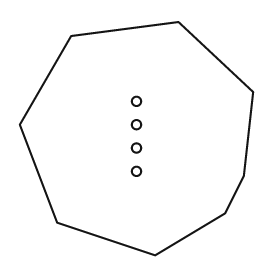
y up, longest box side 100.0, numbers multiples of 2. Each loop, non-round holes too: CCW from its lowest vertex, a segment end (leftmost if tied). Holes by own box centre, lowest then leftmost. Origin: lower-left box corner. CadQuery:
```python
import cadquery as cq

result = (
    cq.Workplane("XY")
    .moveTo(58.0, 0.0)
    .lineTo(88.0, 18.0)
    .lineTo(96.0, 34.0)
    .lineTo(100.0, 70.0)
    .lineTo(68.0, 100.0)
    .lineTo(22.0, 94.0)
    .lineTo(0.0, 56.0)
    .lineTo(16.0, 14.0)
    .close()
    .moveTo(50.0, 36.0)
    .circle(2.0)
    .moveTo(50.0, 46.0)
    .circle(2.0)
    .moveTo(50.0, 56.0)
    .circle(2.0)
    .moveTo(50.0, 66.0)
    .circle(2.0)
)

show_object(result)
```